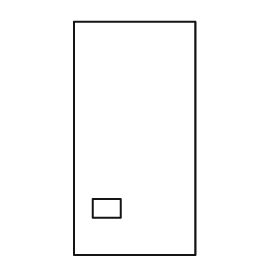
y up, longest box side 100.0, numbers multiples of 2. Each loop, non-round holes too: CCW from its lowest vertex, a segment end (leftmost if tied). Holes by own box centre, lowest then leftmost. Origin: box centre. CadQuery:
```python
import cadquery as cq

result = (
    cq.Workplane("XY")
    .moveTo(-26.0, -50.0)
    .lineTo(26.0, -50.0)
    .lineTo(26.0, 50.0)
    .lineTo(-26.0, 50.0)
    .close()
    .moveTo(-18.0, -34.0)
    .lineTo(-6.0, -34.0)
    .lineTo(-6.0, -26.0)
    .lineTo(-18.0, -26.0)
    .close()
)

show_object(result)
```